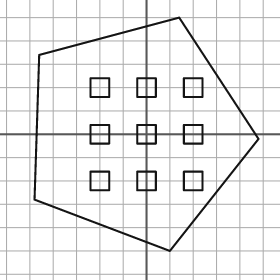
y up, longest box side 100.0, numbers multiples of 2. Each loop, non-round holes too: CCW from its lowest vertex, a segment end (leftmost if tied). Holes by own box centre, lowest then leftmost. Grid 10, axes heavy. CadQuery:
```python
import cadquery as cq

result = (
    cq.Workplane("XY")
    .moveTo(10.0, -50.0)
    .lineTo(48.0, -2.0)
    .lineTo(14.0, 50.0)
    .lineTo(-46.0, 34.0)
    .lineTo(-48.0, -28.0)
    .close()
    .moveTo(-24.0, -24.0)
    .lineTo(-16.0, -24.0)
    .lineTo(-16.0, -16.0)
    .lineTo(-24.0, -16.0)
    .close()
    .moveTo(-4.0, -24.0)
    .lineTo(4.0, -24.0)
    .lineTo(4.0, -16.0)
    .lineTo(-4.0, -16.0)
    .close()
    .moveTo(16.0, -24.0)
    .lineTo(24.0, -24.0)
    .lineTo(24.0, -16.0)
    .lineTo(16.0, -16.0)
    .close()
    .moveTo(-24.0, -4.0)
    .lineTo(-16.0, -4.0)
    .lineTo(-16.0, 4.0)
    .lineTo(-24.0, 4.0)
    .close()
    .moveTo(-4.0, -4.0)
    .lineTo(4.0, -4.0)
    .lineTo(4.0, 4.0)
    .lineTo(-4.0, 4.0)
    .close()
    .moveTo(16.0, -4.0)
    .lineTo(24.0, -4.0)
    .lineTo(24.0, 4.0)
    .lineTo(16.0, 4.0)
    .close()
    .moveTo(-24.0, 16.0)
    .lineTo(-16.0, 16.0)
    .lineTo(-16.0, 24.0)
    .lineTo(-24.0, 24.0)
    .close()
    .moveTo(-4.0, 16.0)
    .lineTo(4.0, 16.0)
    .lineTo(4.0, 24.0)
    .lineTo(-4.0, 24.0)
    .close()
    .moveTo(16.0, 16.0)
    .lineTo(24.0, 16.0)
    .lineTo(24.0, 24.0)
    .lineTo(16.0, 24.0)
    .close()
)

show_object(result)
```